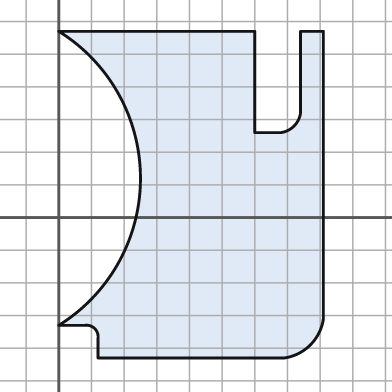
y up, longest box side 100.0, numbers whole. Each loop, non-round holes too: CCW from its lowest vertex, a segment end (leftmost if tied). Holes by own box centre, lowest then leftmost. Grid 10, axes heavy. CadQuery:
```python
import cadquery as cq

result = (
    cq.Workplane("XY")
    .moveTo(12.0, -43.0)
    .lineTo(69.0, -43.0)
    .threePointArc((77.0, -39.0), (81.0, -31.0))
    .lineTo(81.0, 57.0)
    .lineTo(74.0, 57.0)
    .lineTo(74.0, 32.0)
    .threePointArc((72.0, 28.0), (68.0, 26.0))
    .lineTo(60.0, 26.0)
    .lineTo(60.0, 57.0)
    .lineTo(0.0, 57.0)
    .threePointArc((25.0, 12.0), (0.0, -33.0))
    .lineTo(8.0, -33.0)
    .threePointArc((11.0, -34.0), (12.0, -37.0))
    .close()
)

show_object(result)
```